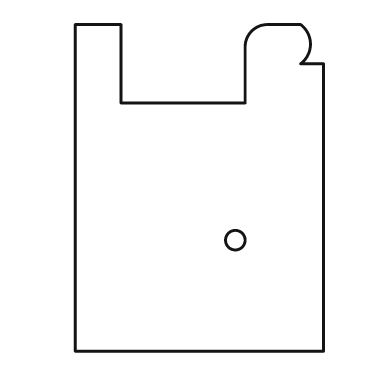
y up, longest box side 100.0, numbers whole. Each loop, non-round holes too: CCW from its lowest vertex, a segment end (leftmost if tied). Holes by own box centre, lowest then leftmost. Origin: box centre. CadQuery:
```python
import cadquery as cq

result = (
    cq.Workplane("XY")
    .moveTo(-38.0, -50.0)
    .lineTo(38.0, -50.0)
    .lineTo(38.0, 38.0)
    .lineTo(31.0, 38.0)
    .threePointArc((34.0, 44.0), (31.0, 50.0))
    .lineTo(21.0, 50.0)
    .threePointArc((16.0, 48.0), (14.0, 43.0))
    .lineTo(14.0, 26.0)
    .lineTo(-24.0, 26.0)
    .lineTo(-24.0, 50.0)
    .lineTo(-38.0, 50.0)
    .close()
    .moveTo(11.0, -16.0)
    .circle(3.0)
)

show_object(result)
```